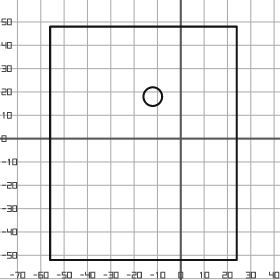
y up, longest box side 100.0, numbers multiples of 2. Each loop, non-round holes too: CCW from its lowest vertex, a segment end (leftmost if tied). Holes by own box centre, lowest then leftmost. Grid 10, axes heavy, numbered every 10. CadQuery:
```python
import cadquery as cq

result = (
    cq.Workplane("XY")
    .moveTo(-56.0, -52.0)
    .lineTo(24.0, -52.0)
    .lineTo(24.0, 48.0)
    .lineTo(-56.0, 48.0)
    .close()
    .moveTo(-12.0, 18.0)
    .circle(4.0)
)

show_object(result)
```